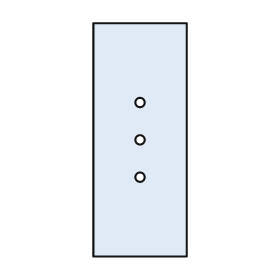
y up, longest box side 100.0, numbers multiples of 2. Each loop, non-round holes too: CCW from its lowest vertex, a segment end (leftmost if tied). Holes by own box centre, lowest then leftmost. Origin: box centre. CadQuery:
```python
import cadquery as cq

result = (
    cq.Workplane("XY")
    .moveTo(-20.0, -50.0)
    .lineTo(20.0, -50.0)
    .lineTo(20.0, 50.0)
    .lineTo(-20.0, 50.0)
    .close()
    .moveTo(0.0, -16.0)
    .circle(2.0)
    .moveTo(0.0, 0.0)
    .circle(2.0)
    .moveTo(0.0, 16.0)
    .circle(2.0)
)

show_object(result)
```